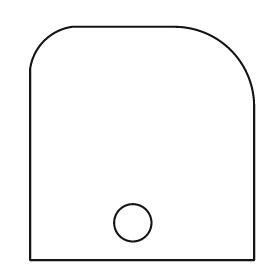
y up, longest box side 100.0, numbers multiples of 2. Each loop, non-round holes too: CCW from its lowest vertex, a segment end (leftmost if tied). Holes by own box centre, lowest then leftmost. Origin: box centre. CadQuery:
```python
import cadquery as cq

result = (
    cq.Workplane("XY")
    .moveTo(-48.0, -50.0)
    .lineTo(48.0, -50.0)
    .lineTo(48.0, 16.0)
    .threePointArc((38.0, 40.0), (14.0, 50.0))
    .lineTo(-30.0, 50.0)
    .threePointArc((-42.0, 44.0), (-48.0, 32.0))
    .close()
    .moveTo(-4.0, -34.0)
    .circle(8.0)
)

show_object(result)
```